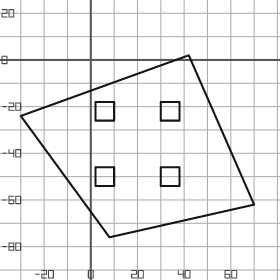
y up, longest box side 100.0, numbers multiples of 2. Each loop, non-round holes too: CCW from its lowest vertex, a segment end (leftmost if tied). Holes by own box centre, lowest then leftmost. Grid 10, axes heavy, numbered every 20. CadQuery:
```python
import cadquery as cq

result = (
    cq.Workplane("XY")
    .moveTo(8.0, -76.0)
    .lineTo(70.0, -62.0)
    .lineTo(42.0, 2.0)
    .lineTo(-30.0, -24.0)
    .close()
    .moveTo(2.0, -54.0)
    .lineTo(10.0, -54.0)
    .lineTo(10.0, -46.0)
    .lineTo(2.0, -46.0)
    .close()
    .moveTo(30.0, -54.0)
    .lineTo(38.0, -54.0)
    .lineTo(38.0, -46.0)
    .lineTo(30.0, -46.0)
    .close()
    .moveTo(2.0, -26.0)
    .lineTo(10.0, -26.0)
    .lineTo(10.0, -18.0)
    .lineTo(2.0, -18.0)
    .close()
    .moveTo(30.0, -26.0)
    .lineTo(38.0, -26.0)
    .lineTo(38.0, -18.0)
    .lineTo(30.0, -18.0)
    .close()
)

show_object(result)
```